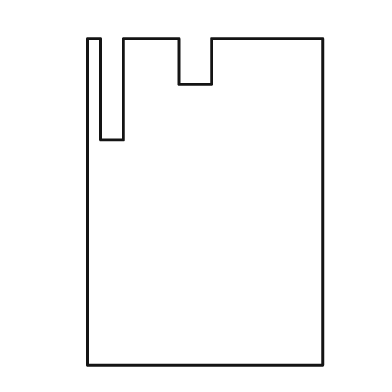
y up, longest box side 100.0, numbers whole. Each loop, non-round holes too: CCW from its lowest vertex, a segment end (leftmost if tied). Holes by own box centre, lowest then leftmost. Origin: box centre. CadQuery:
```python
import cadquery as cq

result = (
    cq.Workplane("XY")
    .moveTo(-36.0, -50.0)
    .lineTo(36.0, -50.0)
    .lineTo(36.0, 50.0)
    .lineTo(2.0, 50.0)
    .lineTo(2.0, 36.0)
    .lineTo(-8.0, 36.0)
    .lineTo(-8.0, 50.0)
    .lineTo(-25.0, 50.0)
    .lineTo(-25.0, 19.0)
    .lineTo(-32.0, 19.0)
    .lineTo(-32.0, 50.0)
    .lineTo(-36.0, 50.0)
    .close()
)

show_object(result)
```